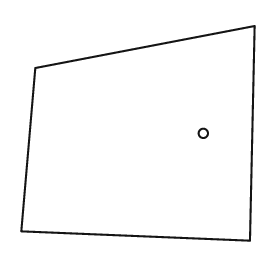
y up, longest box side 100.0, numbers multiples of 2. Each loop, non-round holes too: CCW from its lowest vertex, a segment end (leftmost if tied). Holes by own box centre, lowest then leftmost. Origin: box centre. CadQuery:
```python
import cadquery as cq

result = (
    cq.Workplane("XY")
    .moveTo(48.0, -46.0)
    .lineTo(50.0, 46.0)
    .lineTo(-44.0, 28.0)
    .lineTo(-50.0, -42.0)
    .close()
    .moveTo(28.0, 0.0)
    .circle(2.0)
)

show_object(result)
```